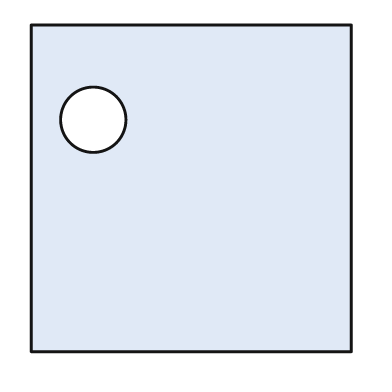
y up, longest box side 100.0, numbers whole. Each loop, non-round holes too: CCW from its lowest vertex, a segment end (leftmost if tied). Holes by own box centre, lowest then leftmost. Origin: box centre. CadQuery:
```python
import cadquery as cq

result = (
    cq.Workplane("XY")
    .moveTo(-49.0, -50.0)
    .lineTo(49.0, -50.0)
    .lineTo(49.0, 50.0)
    .lineTo(-49.0, 50.0)
    .close()
    .moveTo(-30.0, 21.0)
    .circle(10.0)
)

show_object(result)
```